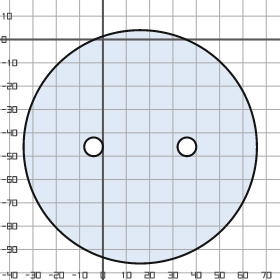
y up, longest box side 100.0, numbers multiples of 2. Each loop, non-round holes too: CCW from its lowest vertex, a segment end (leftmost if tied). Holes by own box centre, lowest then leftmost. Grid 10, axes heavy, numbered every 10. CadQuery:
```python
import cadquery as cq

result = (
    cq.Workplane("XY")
    .moveTo(16.0, -46.0)
    .circle(50.0)
    .moveTo(-4.0, -46.0)
    .circle(4.0)
    .moveTo(36.0, -46.0)
    .circle(4.0)
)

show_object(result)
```